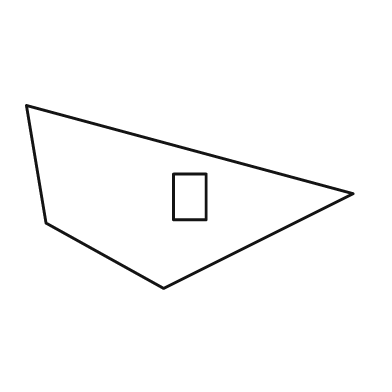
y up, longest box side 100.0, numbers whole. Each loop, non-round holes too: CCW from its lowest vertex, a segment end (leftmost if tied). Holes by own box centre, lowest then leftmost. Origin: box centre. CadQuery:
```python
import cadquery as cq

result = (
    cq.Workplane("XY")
    .moveTo(-8.0, -28.0)
    .lineTo(50.0, 1.0)
    .lineTo(-50.0, 28.0)
    .lineTo(-44.0, -8.0)
    .close()
    .moveTo(-5.0, -7.0)
    .lineTo(5.0, -7.0)
    .lineTo(5.0, 7.0)
    .lineTo(-5.0, 7.0)
    .close()
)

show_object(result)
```